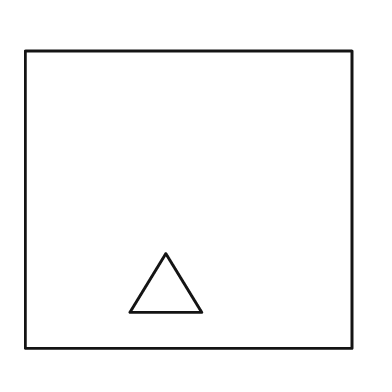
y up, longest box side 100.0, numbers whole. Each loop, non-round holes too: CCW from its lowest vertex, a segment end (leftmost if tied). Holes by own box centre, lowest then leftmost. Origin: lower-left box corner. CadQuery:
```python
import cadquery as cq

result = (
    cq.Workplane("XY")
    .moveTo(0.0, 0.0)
    .lineTo(100.0, 0.0)
    .lineTo(100.0, 91.0)
    .lineTo(0.0, 91.0)
    .close()
    .moveTo(32.0, 11.0)
    .lineTo(54.0, 11.0)
    .lineTo(43.0, 29.0)
    .close()
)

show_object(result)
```